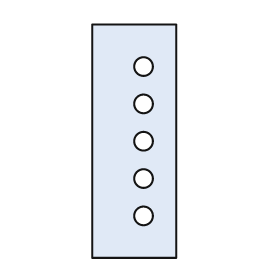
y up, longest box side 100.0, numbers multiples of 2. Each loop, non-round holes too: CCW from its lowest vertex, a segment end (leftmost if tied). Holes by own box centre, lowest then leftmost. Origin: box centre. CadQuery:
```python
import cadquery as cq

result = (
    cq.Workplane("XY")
    .moveTo(-18.0, -50.0)
    .lineTo(18.0, -50.0)
    .lineTo(18.0, 50.0)
    .lineTo(-18.0, 50.0)
    .close()
    .moveTo(4.0, -32.0)
    .circle(4.0)
    .moveTo(4.0, -16.0)
    .circle(4.0)
    .moveTo(4.0, 0.0)
    .circle(4.0)
    .moveTo(4.0, 16.0)
    .circle(4.0)
    .moveTo(4.0, 32.0)
    .circle(4.0)
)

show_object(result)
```